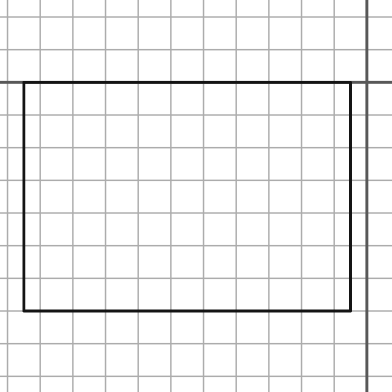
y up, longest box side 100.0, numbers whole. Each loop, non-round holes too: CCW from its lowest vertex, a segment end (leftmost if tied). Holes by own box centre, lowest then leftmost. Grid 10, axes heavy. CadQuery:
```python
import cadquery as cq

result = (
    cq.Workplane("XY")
    .moveTo(-105.0, -70.0)
    .lineTo(-5.0, -70.0)
    .lineTo(-5.0, 0.0)
    .lineTo(-105.0, 0.0)
    .close()
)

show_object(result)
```